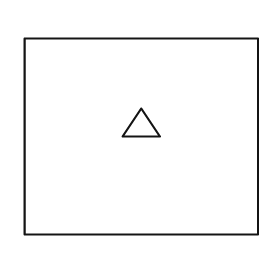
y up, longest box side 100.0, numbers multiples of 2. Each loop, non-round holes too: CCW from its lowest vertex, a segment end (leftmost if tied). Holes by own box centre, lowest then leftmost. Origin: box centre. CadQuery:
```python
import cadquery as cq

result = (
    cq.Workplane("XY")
    .moveTo(-50.0, -42.0)
    .lineTo(50.0, -42.0)
    .lineTo(50.0, 42.0)
    .lineTo(-50.0, 42.0)
    .close()
    .moveTo(-8.0, 0.0)
    .lineTo(8.0, 0.0)
    .lineTo(0.0, 12.0)
    .close()
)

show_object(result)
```